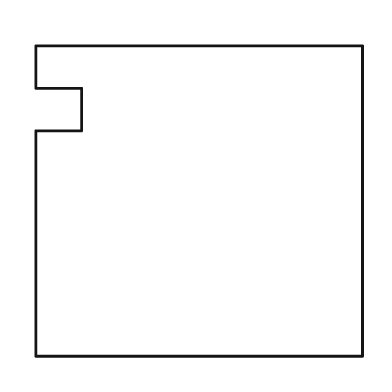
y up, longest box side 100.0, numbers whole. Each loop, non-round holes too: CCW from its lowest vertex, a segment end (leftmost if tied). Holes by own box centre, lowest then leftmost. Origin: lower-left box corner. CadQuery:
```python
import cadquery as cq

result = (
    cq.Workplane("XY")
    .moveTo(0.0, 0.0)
    .lineTo(100.0, 0.0)
    .lineTo(100.0, 95.0)
    .lineTo(0.0, 95.0)
    .lineTo(0.0, 82.0)
    .lineTo(14.0, 82.0)
    .lineTo(14.0, 69.0)
    .lineTo(0.0, 69.0)
    .close()
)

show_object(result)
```